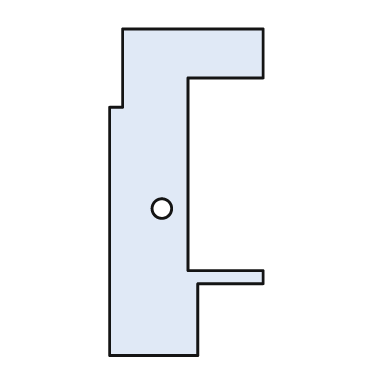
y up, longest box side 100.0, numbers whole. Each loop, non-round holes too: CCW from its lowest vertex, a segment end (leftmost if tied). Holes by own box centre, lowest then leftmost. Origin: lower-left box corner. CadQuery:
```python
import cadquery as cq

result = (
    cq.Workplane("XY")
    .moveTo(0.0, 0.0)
    .lineTo(27.0, 0.0)
    .lineTo(27.0, 22.0)
    .lineTo(47.0, 22.0)
    .lineTo(47.0, 26.0)
    .lineTo(24.0, 26.0)
    .lineTo(24.0, 85.0)
    .lineTo(47.0, 85.0)
    .lineTo(47.0, 100.0)
    .lineTo(4.0, 100.0)
    .lineTo(4.0, 76.0)
    .lineTo(0.0, 76.0)
    .close()
    .moveTo(16.0, 45.0)
    .circle(3.0)
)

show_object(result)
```